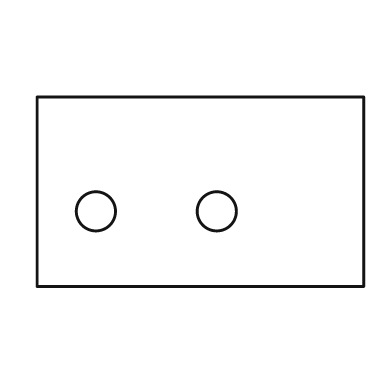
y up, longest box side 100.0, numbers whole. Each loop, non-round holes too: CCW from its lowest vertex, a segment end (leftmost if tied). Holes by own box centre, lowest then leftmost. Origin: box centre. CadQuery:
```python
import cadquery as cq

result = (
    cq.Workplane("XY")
    .moveTo(-50.0, -29.0)
    .lineTo(50.0, -29.0)
    .lineTo(50.0, 29.0)
    .lineTo(-50.0, 29.0)
    .close()
    .moveTo(-32.0, -6.0)
    .circle(6.0)
    .moveTo(5.0, -6.0)
    .circle(6.0)
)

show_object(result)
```